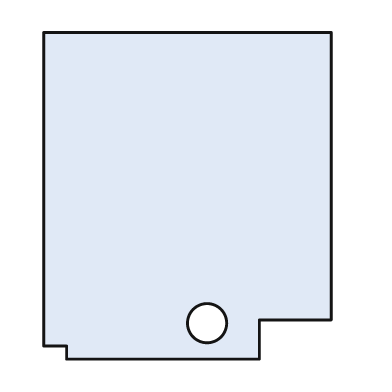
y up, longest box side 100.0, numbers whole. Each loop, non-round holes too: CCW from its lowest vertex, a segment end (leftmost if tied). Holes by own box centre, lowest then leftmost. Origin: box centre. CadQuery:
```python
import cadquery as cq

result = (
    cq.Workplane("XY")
    .moveTo(-37.0, -50.0)
    .lineTo(22.0, -50.0)
    .lineTo(22.0, -38.0)
    .lineTo(44.0, -38.0)
    .lineTo(44.0, 50.0)
    .lineTo(-44.0, 50.0)
    .lineTo(-44.0, -46.0)
    .lineTo(-37.0, -46.0)
    .close()
    .moveTo(6.0, -39.0)
    .circle(6.0)
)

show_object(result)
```